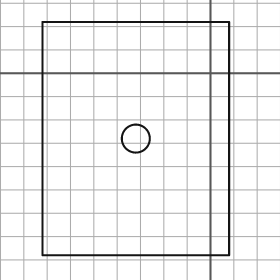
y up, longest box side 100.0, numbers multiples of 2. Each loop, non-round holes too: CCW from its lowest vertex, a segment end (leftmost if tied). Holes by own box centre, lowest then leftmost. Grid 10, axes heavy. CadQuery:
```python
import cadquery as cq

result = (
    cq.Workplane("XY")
    .moveTo(-72.0, -78.0)
    .lineTo(8.0, -78.0)
    .lineTo(8.0, 22.0)
    .lineTo(-72.0, 22.0)
    .close()
    .moveTo(-32.0, -28.0)
    .circle(6.0)
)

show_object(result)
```